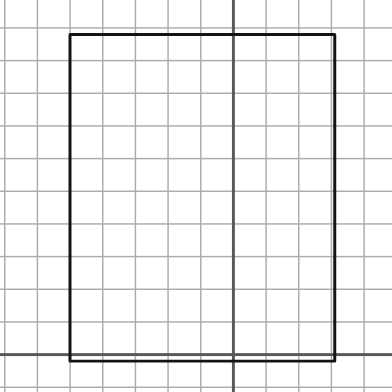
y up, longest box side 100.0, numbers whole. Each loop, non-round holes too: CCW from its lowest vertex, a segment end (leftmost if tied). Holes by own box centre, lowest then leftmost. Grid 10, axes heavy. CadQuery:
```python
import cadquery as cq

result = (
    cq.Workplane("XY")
    .moveTo(-50.0, -2.0)
    .lineTo(31.0, -2.0)
    .lineTo(31.0, 98.0)
    .lineTo(-50.0, 98.0)
    .close()
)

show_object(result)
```